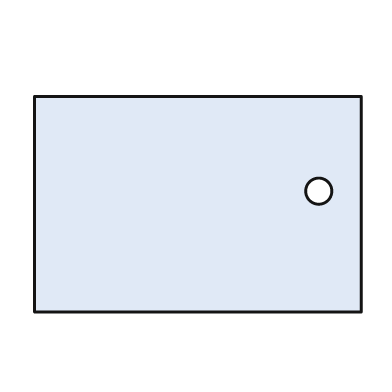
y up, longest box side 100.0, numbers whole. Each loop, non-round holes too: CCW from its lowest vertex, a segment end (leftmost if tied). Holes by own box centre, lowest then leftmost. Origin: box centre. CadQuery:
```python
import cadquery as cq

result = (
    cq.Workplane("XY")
    .moveTo(-50.0, -33.0)
    .lineTo(50.0, -33.0)
    .lineTo(50.0, 33.0)
    .lineTo(-50.0, 33.0)
    .close()
    .moveTo(37.0, 4.0)
    .circle(4.0)
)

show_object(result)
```